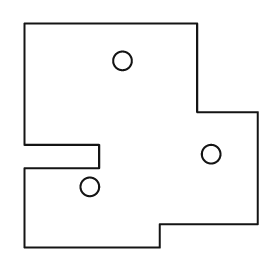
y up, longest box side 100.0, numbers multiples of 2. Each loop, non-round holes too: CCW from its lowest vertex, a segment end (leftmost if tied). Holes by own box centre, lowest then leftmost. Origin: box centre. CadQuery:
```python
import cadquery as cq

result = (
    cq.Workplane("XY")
    .moveTo(-50.0, -48.0)
    .lineTo(8.0, -48.0)
    .lineTo(8.0, -38.0)
    .lineTo(50.0, -38.0)
    .lineTo(50.0, 10.0)
    .lineTo(24.0, 10.0)
    .lineTo(24.0, 48.0)
    .lineTo(-50.0, 48.0)
    .lineTo(-50.0, -4.0)
    .lineTo(-18.0, -4.0)
    .lineTo(-18.0, -14.0)
    .lineTo(-50.0, -14.0)
    .close()
    .moveTo(-22.0, -22.0)
    .circle(4.0)
    .moveTo(30.0, -8.0)
    .circle(4.0)
    .moveTo(-8.0, 32.0)
    .circle(4.0)
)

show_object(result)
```